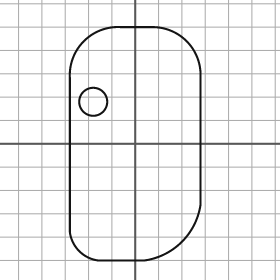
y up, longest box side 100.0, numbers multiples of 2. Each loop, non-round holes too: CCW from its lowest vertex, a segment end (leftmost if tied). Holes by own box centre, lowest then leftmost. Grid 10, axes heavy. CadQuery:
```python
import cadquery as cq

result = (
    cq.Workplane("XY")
    .moveTo(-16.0, -50.0)
    .lineTo(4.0, -50.0)
    .threePointArc((20.0, -42.0), (28.0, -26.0))
    .lineTo(28.0, 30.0)
    .threePointArc((22.0, 44.0), (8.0, 50.0))
    .lineTo(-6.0, 50.0)
    .threePointArc((-22.0, 44.0), (-28.0, 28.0))
    .lineTo(-28.0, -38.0)
    .threePointArc((-24.0, -46.0), (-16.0, -50.0))
    .close()
    .moveTo(-18.0, 18.0)
    .circle(6.0)
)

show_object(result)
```